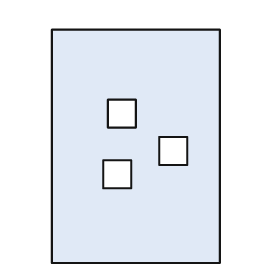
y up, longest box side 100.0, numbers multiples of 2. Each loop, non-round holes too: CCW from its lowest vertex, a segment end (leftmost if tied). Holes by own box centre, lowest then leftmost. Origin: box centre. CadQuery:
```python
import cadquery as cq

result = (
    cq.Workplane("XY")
    .moveTo(-36.0, -50.0)
    .lineTo(36.0, -50.0)
    .lineTo(36.0, 50.0)
    .lineTo(-36.0, 50.0)
    .close()
    .moveTo(-14.0, -18.0)
    .lineTo(-2.0, -18.0)
    .lineTo(-2.0, -6.0)
    .lineTo(-14.0, -6.0)
    .close()
    .moveTo(10.0, -8.0)
    .lineTo(22.0, -8.0)
    .lineTo(22.0, 4.0)
    .lineTo(10.0, 4.0)
    .close()
    .moveTo(-12.0, 8.0)
    .lineTo(0.0, 8.0)
    .lineTo(0.0, 20.0)
    .lineTo(-12.0, 20.0)
    .close()
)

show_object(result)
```